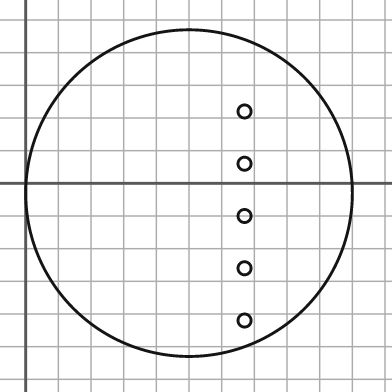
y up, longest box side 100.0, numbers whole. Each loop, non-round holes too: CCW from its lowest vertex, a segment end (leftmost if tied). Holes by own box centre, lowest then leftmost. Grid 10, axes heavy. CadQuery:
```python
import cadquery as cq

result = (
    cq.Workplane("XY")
    .moveTo(50.0, -3.0)
    .circle(50.0)
    .moveTo(67.0, -42.0)
    .circle(2.0)
    .moveTo(67.0, -26.0)
    .circle(2.0)
    .moveTo(67.0, -10.0)
    .circle(2.0)
    .moveTo(67.0, 6.0)
    .circle(2.0)
    .moveTo(67.0, 22.0)
    .circle(2.0)
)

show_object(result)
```